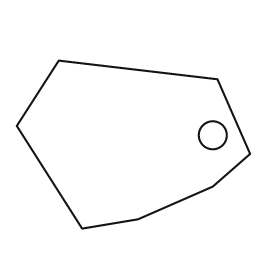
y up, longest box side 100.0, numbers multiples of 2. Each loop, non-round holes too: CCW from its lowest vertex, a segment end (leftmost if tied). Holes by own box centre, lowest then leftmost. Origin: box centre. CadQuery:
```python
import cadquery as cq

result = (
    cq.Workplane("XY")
    .moveTo(-22.0, -36.0)
    .lineTo(2.0, -32.0)
    .lineTo(34.0, -18.0)
    .lineTo(50.0, -4.0)
    .lineTo(36.0, 28.0)
    .lineTo(-32.0, 36.0)
    .lineTo(-50.0, 8.0)
    .close()
    .moveTo(34.0, 4.0)
    .circle(6.0)
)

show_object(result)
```